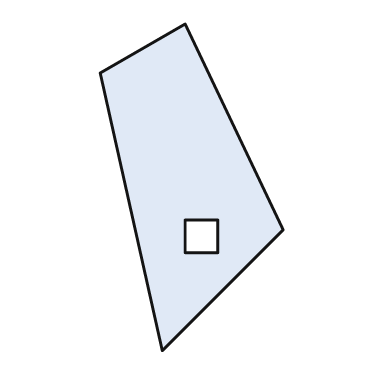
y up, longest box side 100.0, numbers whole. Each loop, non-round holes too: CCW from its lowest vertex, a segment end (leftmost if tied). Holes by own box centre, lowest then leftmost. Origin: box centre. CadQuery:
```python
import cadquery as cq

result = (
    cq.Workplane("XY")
    .moveTo(-9.0, -50.0)
    .lineTo(28.0, -13.0)
    .lineTo(-2.0, 50.0)
    .lineTo(-28.0, 35.0)
    .close()
    .moveTo(-2.0, -20.0)
    .lineTo(8.0, -20.0)
    .lineTo(8.0, -10.0)
    .lineTo(-2.0, -10.0)
    .close()
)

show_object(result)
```